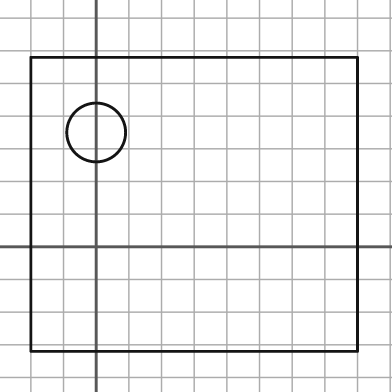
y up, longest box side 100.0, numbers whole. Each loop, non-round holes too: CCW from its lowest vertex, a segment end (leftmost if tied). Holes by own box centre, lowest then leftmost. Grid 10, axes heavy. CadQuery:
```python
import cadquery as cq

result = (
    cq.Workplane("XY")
    .moveTo(-20.0, -32.0)
    .lineTo(80.0, -32.0)
    .lineTo(80.0, 58.0)
    .lineTo(-20.0, 58.0)
    .close()
    .moveTo(0.0, 35.0)
    .circle(9.0)
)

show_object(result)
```